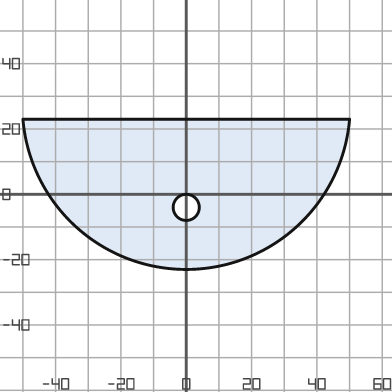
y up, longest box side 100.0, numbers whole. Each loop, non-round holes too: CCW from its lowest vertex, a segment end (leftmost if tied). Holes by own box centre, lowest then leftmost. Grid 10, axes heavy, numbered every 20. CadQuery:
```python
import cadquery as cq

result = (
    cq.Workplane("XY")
    .moveTo(-50.0, 23.0)
    .threePointArc((0.0, -23.0), (50.0, 23.0))
    .close()
    .moveTo(0.0, -4.0)
    .circle(4.0)
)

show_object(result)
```